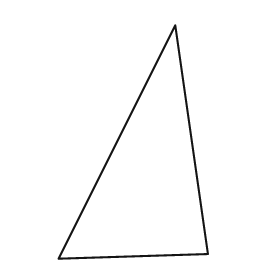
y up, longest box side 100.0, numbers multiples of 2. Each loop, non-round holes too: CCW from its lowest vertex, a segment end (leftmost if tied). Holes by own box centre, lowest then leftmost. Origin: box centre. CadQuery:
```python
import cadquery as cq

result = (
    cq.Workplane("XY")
    .moveTo(-32.0, -50.0)
    .lineTo(32.0, -48.0)
    .lineTo(18.0, 50.0)
    .close()
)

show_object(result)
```